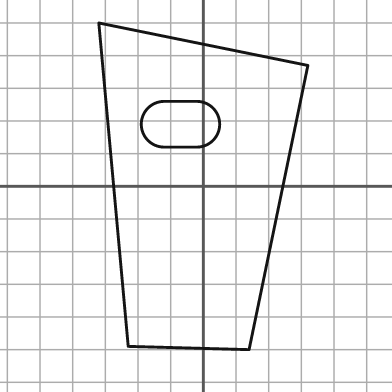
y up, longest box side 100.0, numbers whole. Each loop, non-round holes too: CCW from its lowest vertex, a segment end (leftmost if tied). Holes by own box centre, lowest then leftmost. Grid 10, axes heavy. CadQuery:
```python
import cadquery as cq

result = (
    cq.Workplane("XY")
    .moveTo(14.0, -50.0)
    .lineTo(32.0, 37.0)
    .lineTo(-32.0, 50.0)
    .lineTo(-23.0, -49.0)
    .close()
    .moveTo(-12.0, 12.0)
    .lineTo(-2.0, 12.0)
    .threePointArc((5.0, 19.0), (-2.0, 26.0))
    .lineTo(-12.0, 26.0)
    .threePointArc((-19.0, 19.0), (-12.0, 12.0))
    .close()
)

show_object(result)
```